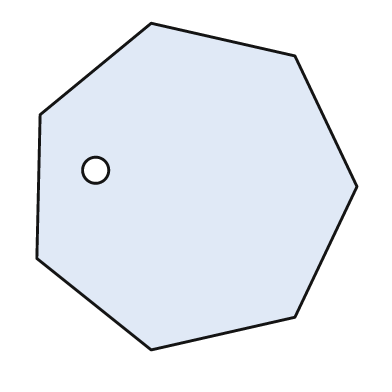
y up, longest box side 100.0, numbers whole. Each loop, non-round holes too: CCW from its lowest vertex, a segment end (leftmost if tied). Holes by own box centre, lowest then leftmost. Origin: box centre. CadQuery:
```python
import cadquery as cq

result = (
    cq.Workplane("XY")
    .moveTo(-14.0, -50.0)
    .lineTo(30.0, -40.0)
    .lineTo(49.0, 0.0)
    .lineTo(30.0, 40.0)
    .lineTo(-14.0, 50.0)
    .lineTo(-48.0, 22.0)
    .lineTo(-49.0, -22.0)
    .close()
    .moveTo(-31.0, 5.0)
    .circle(4.0)
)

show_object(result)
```